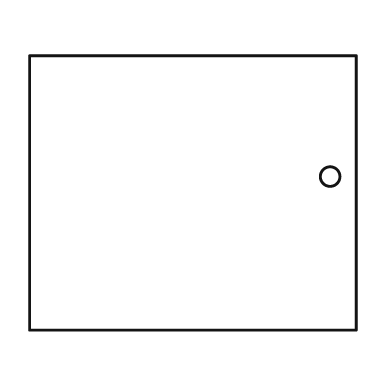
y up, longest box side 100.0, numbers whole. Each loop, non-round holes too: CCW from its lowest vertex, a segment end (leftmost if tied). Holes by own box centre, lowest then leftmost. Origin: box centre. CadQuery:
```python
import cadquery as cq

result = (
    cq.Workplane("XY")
    .moveTo(-50.0, -42.0)
    .lineTo(50.0, -42.0)
    .lineTo(50.0, 42.0)
    .lineTo(-50.0, 42.0)
    .close()
    .moveTo(42.0, 5.0)
    .circle(3.0)
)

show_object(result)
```